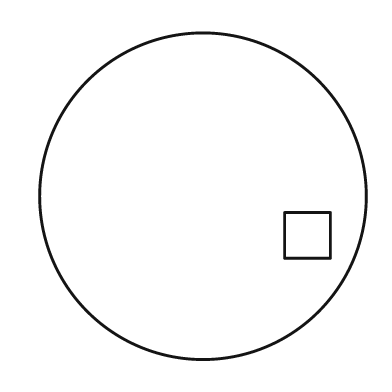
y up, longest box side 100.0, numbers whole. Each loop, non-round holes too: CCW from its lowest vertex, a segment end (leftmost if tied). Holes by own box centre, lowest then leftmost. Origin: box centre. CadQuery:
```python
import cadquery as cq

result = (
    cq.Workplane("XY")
    .moveTo(0.0, 0.0)
    .circle(50.0)
    .moveTo(25.0, -19.0)
    .lineTo(39.0, -19.0)
    .lineTo(39.0, -5.0)
    .lineTo(25.0, -5.0)
    .close()
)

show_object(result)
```